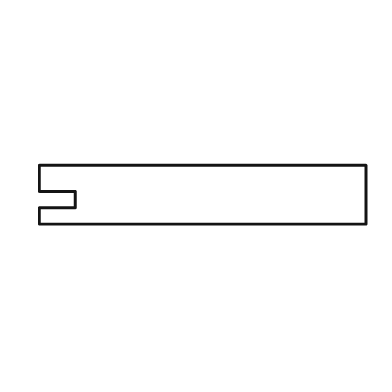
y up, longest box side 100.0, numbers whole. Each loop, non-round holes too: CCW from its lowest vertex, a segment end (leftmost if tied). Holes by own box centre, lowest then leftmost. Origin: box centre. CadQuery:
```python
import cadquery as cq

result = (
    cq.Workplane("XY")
    .moveTo(-50.0, -9.0)
    .lineTo(50.0, -9.0)
    .lineTo(50.0, 9.0)
    .lineTo(-50.0, 9.0)
    .lineTo(-50.0, 1.0)
    .lineTo(-39.0, 1.0)
    .lineTo(-39.0, -4.0)
    .lineTo(-50.0, -4.0)
    .close()
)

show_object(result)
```